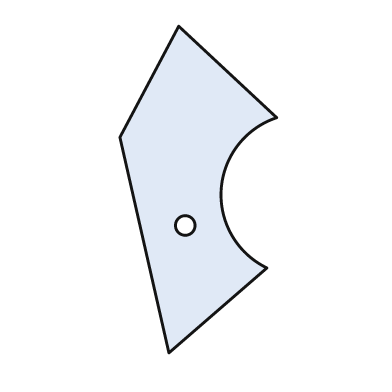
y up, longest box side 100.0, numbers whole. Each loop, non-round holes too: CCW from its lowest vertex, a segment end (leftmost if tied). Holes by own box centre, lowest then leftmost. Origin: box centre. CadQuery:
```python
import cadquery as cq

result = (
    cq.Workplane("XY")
    .moveTo(-9.0, -50.0)
    .lineTo(21.0, -24.0)
    .threePointArc((7.0, 0.0), (24.0, 22.0))
    .lineTo(-6.0, 50.0)
    .lineTo(-24.0, 16.0)
    .close()
    .moveTo(-4.0, -11.0)
    .circle(3.0)
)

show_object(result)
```